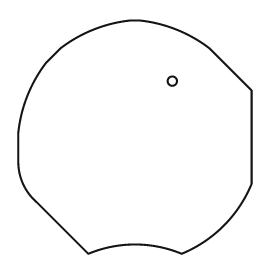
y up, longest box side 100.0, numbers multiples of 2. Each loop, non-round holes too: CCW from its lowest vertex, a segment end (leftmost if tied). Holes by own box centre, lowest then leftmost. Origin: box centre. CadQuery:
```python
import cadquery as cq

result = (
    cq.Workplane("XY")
    .moveTo(-20.0, -50.0)
    .threePointArc((0.0, -46.0), (20.0, -50.0))
    .threePointArc((38.0, -38.0), (50.0, -20.0))
    .lineTo(50.0, 20.0)
    .lineTo(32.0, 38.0)
    .threePointArc((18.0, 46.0), (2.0, 50.0))
    .lineTo(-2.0, 50.0)
    .threePointArc((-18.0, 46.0), (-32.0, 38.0))
    .lineTo(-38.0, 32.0)
    .threePointArc((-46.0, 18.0), (-50.0, 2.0))
    .lineTo(-50.0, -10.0)
    .threePointArc((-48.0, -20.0), (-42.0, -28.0))
    .close()
    .moveTo(16.0, 24.0)
    .circle(2.0)
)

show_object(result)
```